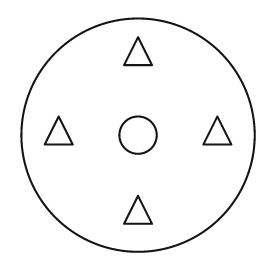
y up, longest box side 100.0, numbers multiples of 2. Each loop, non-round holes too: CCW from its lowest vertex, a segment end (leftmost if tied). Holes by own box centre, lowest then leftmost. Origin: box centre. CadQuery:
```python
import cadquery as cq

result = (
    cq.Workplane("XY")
    .moveTo(0.0, 0.0)
    .circle(50.0)
    .moveTo(-6.0, -38.0)
    .lineTo(6.0, -38.0)
    .lineTo(0.0, -26.0)
    .close()
    .moveTo(0.0, 0.0)
    .circle(8.0)
    .moveTo(-40.0, -4.0)
    .lineTo(-28.0, -4.0)
    .lineTo(-34.0, 8.0)
    .close()
    .moveTo(28.0, -4.0)
    .lineTo(40.0, -4.0)
    .lineTo(34.0, 8.0)
    .close()
    .moveTo(-6.0, 30.0)
    .lineTo(6.0, 30.0)
    .lineTo(0.0, 42.0)
    .close()
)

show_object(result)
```